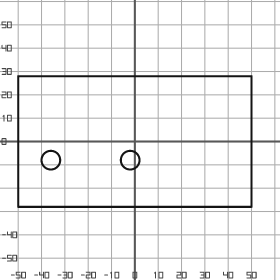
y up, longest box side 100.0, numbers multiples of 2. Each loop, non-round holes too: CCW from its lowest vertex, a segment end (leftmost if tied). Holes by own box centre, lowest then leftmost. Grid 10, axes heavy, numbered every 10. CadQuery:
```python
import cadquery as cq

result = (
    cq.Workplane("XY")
    .moveTo(-50.0, -28.0)
    .lineTo(50.0, -28.0)
    .lineTo(50.0, 28.0)
    .lineTo(-50.0, 28.0)
    .close()
    .moveTo(-36.0, -8.0)
    .circle(4.0)
    .moveTo(-2.0, -8.0)
    .circle(4.0)
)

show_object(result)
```